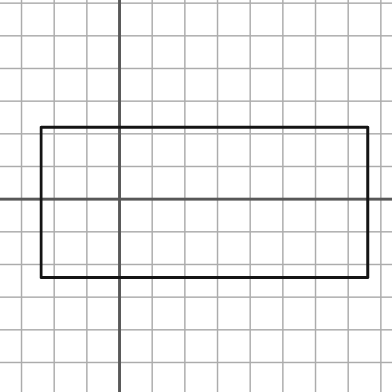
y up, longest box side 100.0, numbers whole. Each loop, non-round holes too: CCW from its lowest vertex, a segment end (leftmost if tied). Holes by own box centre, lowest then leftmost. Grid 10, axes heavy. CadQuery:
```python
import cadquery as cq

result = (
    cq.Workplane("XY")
    .moveTo(-24.0, -24.0)
    .lineTo(76.0, -24.0)
    .lineTo(76.0, 22.0)
    .lineTo(-24.0, 22.0)
    .close()
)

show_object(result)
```